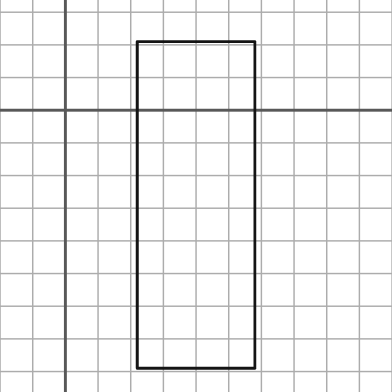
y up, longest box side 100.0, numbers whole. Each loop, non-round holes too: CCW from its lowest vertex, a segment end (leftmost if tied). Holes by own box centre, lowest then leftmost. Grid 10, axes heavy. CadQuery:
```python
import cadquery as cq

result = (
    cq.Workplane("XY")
    .moveTo(22.0, -79.0)
    .lineTo(58.0, -79.0)
    .lineTo(58.0, 21.0)
    .lineTo(22.0, 21.0)
    .close()
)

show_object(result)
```